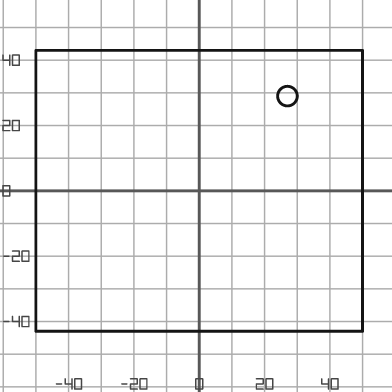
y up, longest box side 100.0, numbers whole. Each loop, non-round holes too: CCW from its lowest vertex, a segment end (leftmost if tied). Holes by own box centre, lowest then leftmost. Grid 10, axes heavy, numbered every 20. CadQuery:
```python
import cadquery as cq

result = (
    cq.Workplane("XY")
    .moveTo(-50.0, -43.0)
    .lineTo(50.0, -43.0)
    .lineTo(50.0, 43.0)
    .lineTo(-50.0, 43.0)
    .close()
    .moveTo(27.0, 29.0)
    .circle(3.0)
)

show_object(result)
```